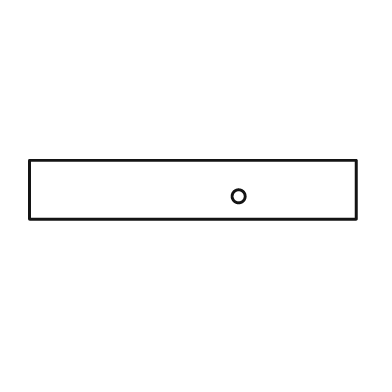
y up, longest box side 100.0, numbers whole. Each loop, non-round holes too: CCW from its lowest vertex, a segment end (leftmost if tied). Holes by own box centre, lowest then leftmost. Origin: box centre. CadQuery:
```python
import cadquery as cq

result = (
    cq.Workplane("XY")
    .moveTo(-50.0, -9.0)
    .lineTo(50.0, -9.0)
    .lineTo(50.0, 9.0)
    .lineTo(-50.0, 9.0)
    .close()
    .moveTo(14.0, -2.0)
    .circle(2.0)
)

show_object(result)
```